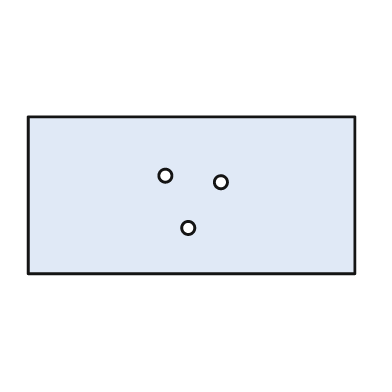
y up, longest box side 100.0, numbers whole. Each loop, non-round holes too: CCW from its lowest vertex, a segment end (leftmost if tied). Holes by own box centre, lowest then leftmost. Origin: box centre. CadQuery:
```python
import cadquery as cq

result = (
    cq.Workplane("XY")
    .moveTo(-50.0, -24.0)
    .lineTo(50.0, -24.0)
    .lineTo(50.0, 24.0)
    .lineTo(-50.0, 24.0)
    .close()
    .moveTo(-1.0, -10.0)
    .circle(2.0)
    .moveTo(9.0, 4.0)
    .circle(2.0)
    .moveTo(-8.0, 6.0)
    .circle(2.0)
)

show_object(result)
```